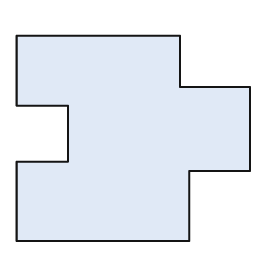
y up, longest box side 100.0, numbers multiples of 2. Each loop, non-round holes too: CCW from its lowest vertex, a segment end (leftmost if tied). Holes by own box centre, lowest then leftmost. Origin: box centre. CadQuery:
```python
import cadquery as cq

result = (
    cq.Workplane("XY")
    .moveTo(-50.0, -44.0)
    .lineTo(24.0, -44.0)
    .lineTo(24.0, -14.0)
    .lineTo(50.0, -14.0)
    .lineTo(50.0, 22.0)
    .lineTo(20.0, 22.0)
    .lineTo(20.0, 44.0)
    .lineTo(-50.0, 44.0)
    .lineTo(-50.0, 14.0)
    .lineTo(-28.0, 14.0)
    .lineTo(-28.0, -10.0)
    .lineTo(-50.0, -10.0)
    .close()
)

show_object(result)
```